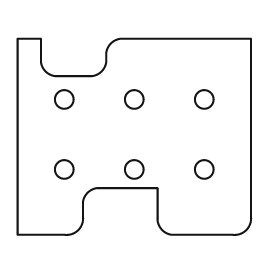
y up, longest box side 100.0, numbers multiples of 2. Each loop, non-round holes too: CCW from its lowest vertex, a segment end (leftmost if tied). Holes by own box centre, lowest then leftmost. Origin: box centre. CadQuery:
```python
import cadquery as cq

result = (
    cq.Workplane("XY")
    .moveTo(-50.0, -42.0)
    .lineTo(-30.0, -42.0)
    .threePointArc((-24.0, -40.0), (-22.0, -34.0))
    .lineTo(-22.0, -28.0)
    .threePointArc((-20.0, -24.0), (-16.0, -22.0))
    .lineTo(10.0, -22.0)
    .lineTo(10.0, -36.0)
    .threePointArc((12.0, -40.0), (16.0, -42.0))
    .lineTo(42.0, -42.0)
    .threePointArc((48.0, -40.0), (50.0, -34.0))
    .lineTo(50.0, 42.0)
    .lineTo(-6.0, 42.0)
    .threePointArc((-10.0, 40.0), (-12.0, 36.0))
    .lineTo(-12.0, 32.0)
    .threePointArc((-14.0, 28.0), (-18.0, 26.0))
    .lineTo(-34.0, 26.0)
    .threePointArc((-38.0, 28.0), (-40.0, 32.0))
    .lineTo(-40.0, 42.0)
    .lineTo(-50.0, 42.0)
    .close()
    .moveTo(-30.0, -14.0)
    .circle(4.0)
    .moveTo(0.0, -14.0)
    .circle(4.0)
    .moveTo(30.0, -14.0)
    .circle(4.0)
    .moveTo(-30.0, 16.0)
    .circle(4.0)
    .moveTo(0.0, 16.0)
    .circle(4.0)
    .moveTo(30.0, 16.0)
    .circle(4.0)
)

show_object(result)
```